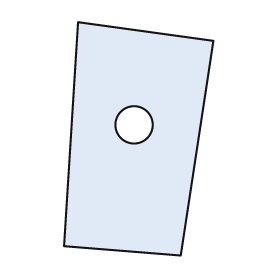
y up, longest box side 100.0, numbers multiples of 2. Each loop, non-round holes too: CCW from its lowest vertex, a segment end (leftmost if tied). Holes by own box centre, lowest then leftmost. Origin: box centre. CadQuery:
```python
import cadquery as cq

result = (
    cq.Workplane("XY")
    .moveTo(18.0, -50.0)
    .lineTo(32.0, 42.0)
    .lineTo(-26.0, 50.0)
    .lineTo(-32.0, -46.0)
    .close()
    .moveTo(-2.0, 6.0)
    .circle(8.0)
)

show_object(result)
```